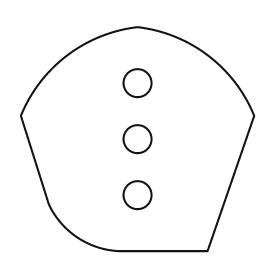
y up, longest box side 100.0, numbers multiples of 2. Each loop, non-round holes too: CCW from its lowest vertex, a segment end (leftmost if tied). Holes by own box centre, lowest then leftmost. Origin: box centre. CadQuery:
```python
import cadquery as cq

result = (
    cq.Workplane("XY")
    .moveTo(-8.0, -48.0)
    .lineTo(30.0, -48.0)
    .lineTo(50.0, 10.0)
    .threePointArc((30.0, 36.0), (0.0, 48.0))
    .threePointArc((-30.0, 36.0), (-50.0, 10.0))
    .lineTo(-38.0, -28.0)
    .threePointArc((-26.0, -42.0), (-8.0, -48.0))
    .close()
    .moveTo(0.0, -24.0)
    .circle(6.0)
    .moveTo(0.0, 0.0)
    .circle(6.0)
    .moveTo(0.0, 24.0)
    .circle(6.0)
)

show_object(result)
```